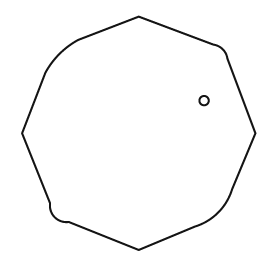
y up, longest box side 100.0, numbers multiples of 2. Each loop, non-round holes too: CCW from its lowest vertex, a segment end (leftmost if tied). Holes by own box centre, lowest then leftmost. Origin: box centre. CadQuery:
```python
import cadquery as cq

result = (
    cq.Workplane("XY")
    .moveTo(0.0, -50.0)
    .lineTo(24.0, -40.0)
    .threePointArc((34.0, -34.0), (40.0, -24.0))
    .lineTo(50.0, 0.0)
    .lineTo(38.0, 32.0)
    .threePointArc((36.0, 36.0), (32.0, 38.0))
    .lineTo(0.0, 50.0)
    .lineTo(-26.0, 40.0)
    .threePointArc((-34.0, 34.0), (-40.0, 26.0))
    .lineTo(-50.0, 0.0)
    .lineTo(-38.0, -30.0)
    .threePointArc((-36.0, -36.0), (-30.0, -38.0))
    .close()
    .moveTo(28.0, 14.0)
    .circle(2.0)
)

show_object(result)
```